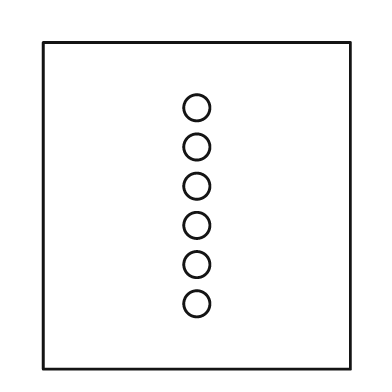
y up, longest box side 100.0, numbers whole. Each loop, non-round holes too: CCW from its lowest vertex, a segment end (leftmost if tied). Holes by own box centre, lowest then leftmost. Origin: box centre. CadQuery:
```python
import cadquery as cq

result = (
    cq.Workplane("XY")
    .moveTo(-47.0, -50.0)
    .lineTo(47.0, -50.0)
    .lineTo(47.0, 50.0)
    .lineTo(-47.0, 50.0)
    .close()
    .moveTo(0.0, -30.0)
    .circle(4.0)
    .moveTo(0.0, -18.0)
    .circle(4.0)
    .moveTo(0.0, -6.0)
    .circle(4.0)
    .moveTo(0.0, 6.0)
    .circle(4.0)
    .moveTo(0.0, 18.0)
    .circle(4.0)
    .moveTo(0.0, 30.0)
    .circle(4.0)
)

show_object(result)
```